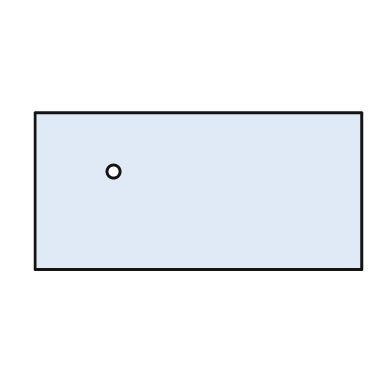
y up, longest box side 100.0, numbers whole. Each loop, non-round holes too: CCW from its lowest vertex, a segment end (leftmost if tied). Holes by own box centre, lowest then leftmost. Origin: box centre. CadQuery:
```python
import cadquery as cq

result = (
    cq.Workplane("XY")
    .moveTo(-50.0, -24.0)
    .lineTo(50.0, -24.0)
    .lineTo(50.0, 24.0)
    .lineTo(-50.0, 24.0)
    .close()
    .moveTo(-26.0, 6.0)
    .circle(2.0)
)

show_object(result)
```